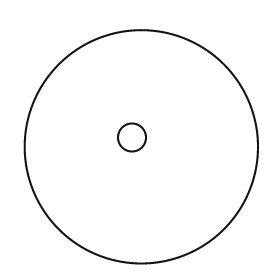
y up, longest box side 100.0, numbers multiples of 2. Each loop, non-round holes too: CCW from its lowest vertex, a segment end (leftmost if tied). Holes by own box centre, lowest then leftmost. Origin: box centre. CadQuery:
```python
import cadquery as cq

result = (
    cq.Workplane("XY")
    .moveTo(0.0, 0.0)
    .circle(50.0)
    .moveTo(-4.0, 4.0)
    .circle(6.0)
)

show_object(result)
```